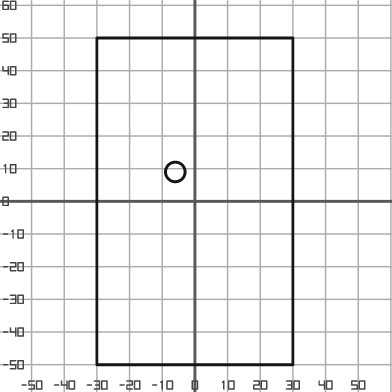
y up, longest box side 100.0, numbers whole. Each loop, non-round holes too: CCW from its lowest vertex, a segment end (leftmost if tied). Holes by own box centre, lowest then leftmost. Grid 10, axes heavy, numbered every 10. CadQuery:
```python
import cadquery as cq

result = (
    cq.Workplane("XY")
    .moveTo(-30.0, -50.0)
    .lineTo(30.0, -50.0)
    .lineTo(30.0, 50.0)
    .lineTo(-30.0, 50.0)
    .close()
    .moveTo(-6.0, 9.0)
    .circle(3.0)
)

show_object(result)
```